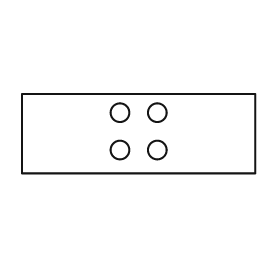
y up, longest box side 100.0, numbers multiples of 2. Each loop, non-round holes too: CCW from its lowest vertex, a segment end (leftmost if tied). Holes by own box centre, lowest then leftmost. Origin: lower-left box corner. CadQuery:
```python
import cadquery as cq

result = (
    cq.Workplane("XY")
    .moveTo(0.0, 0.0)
    .lineTo(100.0, 0.0)
    .lineTo(100.0, 34.0)
    .lineTo(0.0, 34.0)
    .close()
    .moveTo(42.0, 10.0)
    .circle(4.0)
    .moveTo(58.0, 10.0)
    .circle(4.0)
    .moveTo(42.0, 26.0)
    .circle(4.0)
    .moveTo(58.0, 26.0)
    .circle(4.0)
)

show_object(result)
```